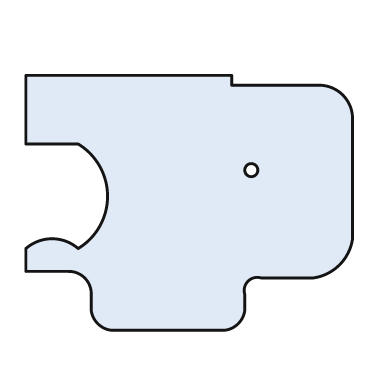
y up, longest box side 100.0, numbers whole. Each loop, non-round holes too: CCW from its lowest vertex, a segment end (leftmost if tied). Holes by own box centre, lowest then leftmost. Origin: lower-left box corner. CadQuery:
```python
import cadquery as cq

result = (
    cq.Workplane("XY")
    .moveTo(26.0, 0.0)
    .lineTo(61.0, 0.0)
    .threePointArc((65.0, 2.0), (67.0, 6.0))
    .lineTo(67.0, 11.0)
    .threePointArc((68.0, 15.0), (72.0, 16.0))
    .lineTo(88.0, 16.0)
    .threePointArc((96.0, 20.0), (100.0, 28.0))
    .lineTo(100.0, 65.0)
    .threePointArc((97.0, 72.0), (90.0, 75.0))
    .lineTo(63.0, 75.0)
    .lineTo(63.0, 78.0)
    .lineTo(0.0, 78.0)
    .lineTo(0.0, 57.0)
    .lineTo(16.0, 57.0)
    .threePointArc((25.0, 41.0), (16.0, 25.0))
    .threePointArc((8.0, 28.0), (0.0, 25.0))
    .lineTo(0.0, 18.0)
    .lineTo(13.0, 18.0)
    .threePointArc((18.0, 16.0), (20.0, 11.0))
    .lineTo(20.0, 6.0)
    .threePointArc((22.0, 2.0), (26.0, 0.0))
    .close()
    .moveTo(69.0, 49.0)
    .circle(2.0)
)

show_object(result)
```